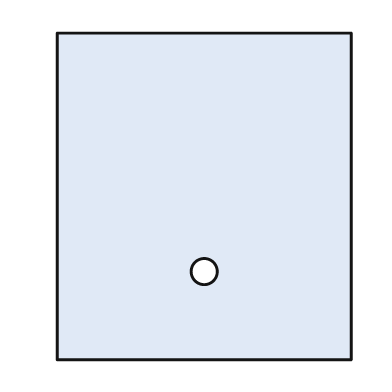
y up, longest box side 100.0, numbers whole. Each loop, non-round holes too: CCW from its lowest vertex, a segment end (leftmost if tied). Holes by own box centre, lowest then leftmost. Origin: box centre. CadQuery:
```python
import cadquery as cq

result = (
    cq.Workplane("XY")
    .moveTo(-45.0, -50.0)
    .lineTo(45.0, -50.0)
    .lineTo(45.0, 50.0)
    .lineTo(-45.0, 50.0)
    .close()
    .moveTo(0.0, -23.0)
    .circle(4.0)
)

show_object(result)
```